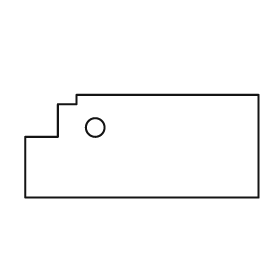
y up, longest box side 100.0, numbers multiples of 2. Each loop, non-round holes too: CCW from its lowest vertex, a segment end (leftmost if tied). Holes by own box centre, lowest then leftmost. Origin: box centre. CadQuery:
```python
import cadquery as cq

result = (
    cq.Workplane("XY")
    .moveTo(-50.0, -22.0)
    .lineTo(50.0, -22.0)
    .lineTo(50.0, 22.0)
    .lineTo(-28.0, 22.0)
    .lineTo(-28.0, 18.0)
    .lineTo(-36.0, 18.0)
    .lineTo(-36.0, 4.0)
    .lineTo(-50.0, 4.0)
    .close()
    .moveTo(-20.0, 8.0)
    .circle(4.0)
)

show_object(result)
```